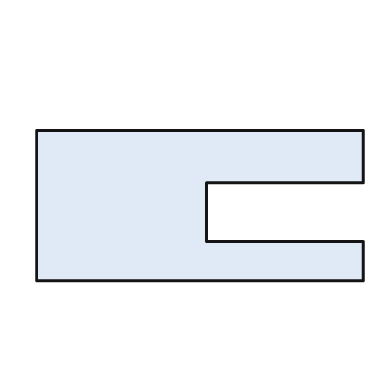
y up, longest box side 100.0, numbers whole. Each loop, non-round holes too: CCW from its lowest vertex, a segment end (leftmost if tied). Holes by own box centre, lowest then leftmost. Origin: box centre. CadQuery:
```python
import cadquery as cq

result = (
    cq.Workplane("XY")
    .moveTo(-50.0, -23.0)
    .lineTo(50.0, -23.0)
    .lineTo(50.0, -11.0)
    .lineTo(2.0, -11.0)
    .lineTo(2.0, 7.0)
    .lineTo(50.0, 7.0)
    .lineTo(50.0, 23.0)
    .lineTo(-50.0, 23.0)
    .close()
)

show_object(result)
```